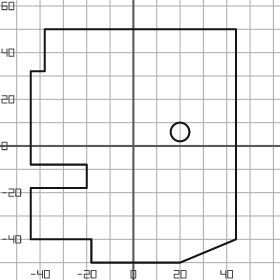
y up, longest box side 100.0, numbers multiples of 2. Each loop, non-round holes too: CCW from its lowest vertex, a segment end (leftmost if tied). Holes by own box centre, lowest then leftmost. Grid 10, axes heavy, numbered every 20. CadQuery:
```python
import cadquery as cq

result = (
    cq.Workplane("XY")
    .moveTo(-18.0, -50.0)
    .lineTo(20.0, -50.0)
    .lineTo(44.0, -40.0)
    .lineTo(44.0, 50.0)
    .lineTo(-38.0, 50.0)
    .lineTo(-38.0, 32.0)
    .lineTo(-44.0, 32.0)
    .lineTo(-44.0, -8.0)
    .lineTo(-20.0, -8.0)
    .lineTo(-20.0, -18.0)
    .lineTo(-44.0, -18.0)
    .lineTo(-44.0, -40.0)
    .lineTo(-18.0, -40.0)
    .close()
    .moveTo(20.0, 6.0)
    .circle(4.0)
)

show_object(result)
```